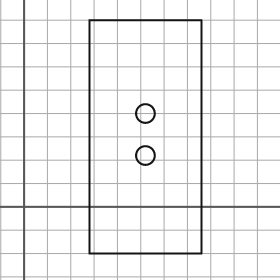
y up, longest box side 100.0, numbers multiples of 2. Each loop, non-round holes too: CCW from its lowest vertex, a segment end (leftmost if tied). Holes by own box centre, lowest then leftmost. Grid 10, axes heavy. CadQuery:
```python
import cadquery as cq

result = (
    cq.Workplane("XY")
    .moveTo(28.0, -20.0)
    .lineTo(76.0, -20.0)
    .lineTo(76.0, 80.0)
    .lineTo(28.0, 80.0)
    .close()
    .moveTo(52.0, 22.0)
    .circle(4.0)
    .moveTo(52.0, 40.0)
    .circle(4.0)
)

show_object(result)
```